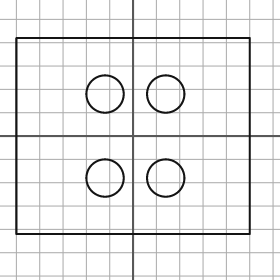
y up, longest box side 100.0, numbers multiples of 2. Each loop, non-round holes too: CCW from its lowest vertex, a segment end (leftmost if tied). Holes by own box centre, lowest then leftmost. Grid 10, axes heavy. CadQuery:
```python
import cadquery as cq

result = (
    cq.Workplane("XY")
    .moveTo(-50.0, -42.0)
    .lineTo(50.0, -42.0)
    .lineTo(50.0, 42.0)
    .lineTo(-50.0, 42.0)
    .close()
    .moveTo(-12.0, -18.0)
    .circle(8.0)
    .moveTo(14.0, -18.0)
    .circle(8.0)
    .moveTo(-12.0, 18.0)
    .circle(8.0)
    .moveTo(14.0, 18.0)
    .circle(8.0)
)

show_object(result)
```